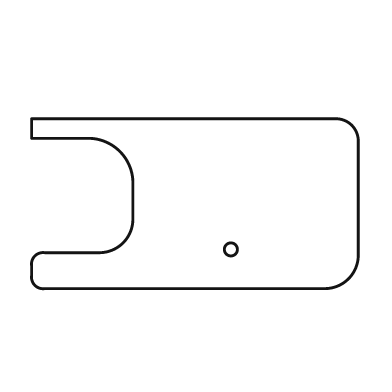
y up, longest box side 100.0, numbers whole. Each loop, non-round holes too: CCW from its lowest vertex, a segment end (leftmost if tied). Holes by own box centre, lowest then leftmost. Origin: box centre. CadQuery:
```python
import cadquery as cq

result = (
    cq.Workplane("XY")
    .moveTo(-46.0, -26.0)
    .lineTo(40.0, -26.0)
    .threePointArc((47.0, -23.0), (50.0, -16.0))
    .lineTo(50.0, 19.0)
    .threePointArc((48.0, 24.0), (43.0, 26.0))
    .lineTo(-50.0, 26.0)
    .lineTo(-50.0, 20.0)
    .lineTo(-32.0, 20.0)
    .threePointArc((-23.0, 16.0), (-19.0, 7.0))
    .lineTo(-19.0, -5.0)
    .threePointArc((-22.0, -12.0), (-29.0, -15.0))
    .lineTo(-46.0, -15.0)
    .threePointArc((-49.0, -16.0), (-50.0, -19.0))
    .lineTo(-50.0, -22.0)
    .threePointArc((-49.0, -25.0), (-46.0, -26.0))
    .close()
    .moveTo(11.0, -14.0)
    .circle(2.0)
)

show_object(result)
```